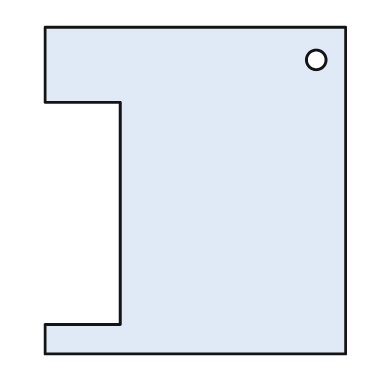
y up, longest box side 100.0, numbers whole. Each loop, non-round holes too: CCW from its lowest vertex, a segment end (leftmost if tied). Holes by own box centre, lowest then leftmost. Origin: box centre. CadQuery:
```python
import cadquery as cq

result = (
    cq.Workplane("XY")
    .moveTo(-46.0, -50.0)
    .lineTo(46.0, -50.0)
    .lineTo(46.0, 50.0)
    .lineTo(-46.0, 50.0)
    .lineTo(-46.0, 27.0)
    .lineTo(-23.0, 27.0)
    .lineTo(-23.0, -41.0)
    .lineTo(-46.0, -41.0)
    .close()
    .moveTo(37.0, 40.0)
    .circle(3.0)
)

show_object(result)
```